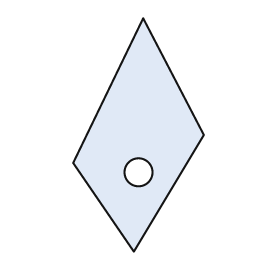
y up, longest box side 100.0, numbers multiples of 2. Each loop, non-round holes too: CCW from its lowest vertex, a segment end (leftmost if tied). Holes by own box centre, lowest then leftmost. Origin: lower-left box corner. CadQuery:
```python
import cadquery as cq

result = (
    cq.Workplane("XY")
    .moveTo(26.0, 0.0)
    .lineTo(56.0, 50.0)
    .lineTo(30.0, 100.0)
    .lineTo(0.0, 38.0)
    .close()
    .moveTo(28.0, 34.0)
    .circle(6.0)
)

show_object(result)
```